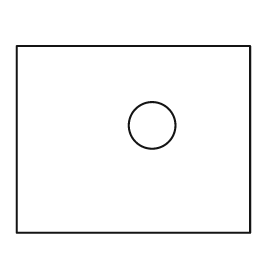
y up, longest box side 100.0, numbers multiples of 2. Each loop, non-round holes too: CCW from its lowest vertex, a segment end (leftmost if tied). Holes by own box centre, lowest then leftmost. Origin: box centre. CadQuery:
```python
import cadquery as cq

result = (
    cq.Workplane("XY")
    .moveTo(-50.0, -40.0)
    .lineTo(50.0, -40.0)
    .lineTo(50.0, 40.0)
    .lineTo(-50.0, 40.0)
    .close()
    .moveTo(8.0, 6.0)
    .circle(10.0)
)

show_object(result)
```